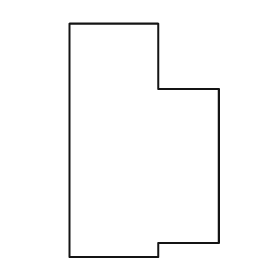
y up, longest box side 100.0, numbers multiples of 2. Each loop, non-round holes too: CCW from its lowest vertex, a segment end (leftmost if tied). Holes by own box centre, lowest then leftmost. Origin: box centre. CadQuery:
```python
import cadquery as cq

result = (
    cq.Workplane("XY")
    .moveTo(-32.0, -50.0)
    .lineTo(6.0, -50.0)
    .lineTo(6.0, -44.0)
    .lineTo(32.0, -44.0)
    .lineTo(32.0, 22.0)
    .lineTo(6.0, 22.0)
    .lineTo(6.0, 50.0)
    .lineTo(-32.0, 50.0)
    .close()
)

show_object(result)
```